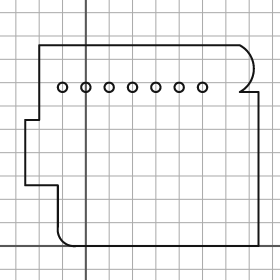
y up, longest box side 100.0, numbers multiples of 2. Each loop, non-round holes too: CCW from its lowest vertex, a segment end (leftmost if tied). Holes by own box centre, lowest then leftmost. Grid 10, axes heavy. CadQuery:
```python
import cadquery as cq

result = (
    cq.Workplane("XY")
    .moveTo(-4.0, 0.0)
    .lineTo(74.0, 0.0)
    .lineTo(74.0, 66.0)
    .lineTo(66.0, 66.0)
    .threePointArc((72.0, 76.0), (66.0, 86.0))
    .lineTo(-20.0, 86.0)
    .lineTo(-20.0, 54.0)
    .lineTo(-26.0, 54.0)
    .lineTo(-26.0, 26.0)
    .lineTo(-12.0, 26.0)
    .lineTo(-12.0, 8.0)
    .threePointArc((-10.0, 2.0), (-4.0, 0.0))
    .close()
    .moveTo(-10.0, 68.0)
    .circle(2.0)
    .moveTo(0.0, 68.0)
    .circle(2.0)
    .moveTo(10.0, 68.0)
    .circle(2.0)
    .moveTo(20.0, 68.0)
    .circle(2.0)
    .moveTo(30.0, 68.0)
    .circle(2.0)
    .moveTo(40.0, 68.0)
    .circle(2.0)
    .moveTo(50.0, 68.0)
    .circle(2.0)
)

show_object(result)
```